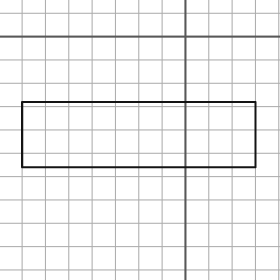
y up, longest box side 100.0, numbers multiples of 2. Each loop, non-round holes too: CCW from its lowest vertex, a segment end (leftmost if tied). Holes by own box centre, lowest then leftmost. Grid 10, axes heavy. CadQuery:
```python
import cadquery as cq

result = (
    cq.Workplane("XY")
    .moveTo(-70.0, -56.0)
    .lineTo(30.0, -56.0)
    .lineTo(30.0, -28.0)
    .lineTo(-70.0, -28.0)
    .close()
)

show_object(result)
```